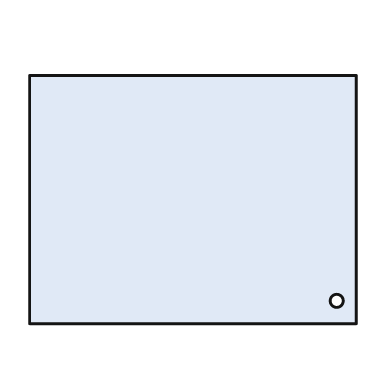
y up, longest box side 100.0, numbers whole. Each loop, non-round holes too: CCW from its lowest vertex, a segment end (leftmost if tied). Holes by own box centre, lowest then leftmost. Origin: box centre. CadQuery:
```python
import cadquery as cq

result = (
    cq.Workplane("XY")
    .moveTo(-50.0, -38.0)
    .lineTo(50.0, -38.0)
    .lineTo(50.0, 38.0)
    .lineTo(-50.0, 38.0)
    .close()
    .moveTo(44.0, -31.0)
    .circle(2.0)
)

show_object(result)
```